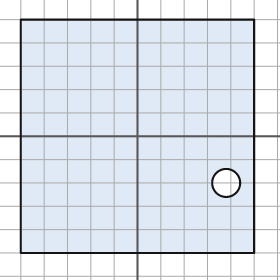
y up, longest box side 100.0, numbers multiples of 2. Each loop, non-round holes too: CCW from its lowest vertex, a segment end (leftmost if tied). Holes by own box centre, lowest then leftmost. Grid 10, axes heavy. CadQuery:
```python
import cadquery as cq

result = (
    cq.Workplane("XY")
    .moveTo(-50.0, -50.0)
    .lineTo(50.0, -50.0)
    .lineTo(50.0, 50.0)
    .lineTo(-50.0, 50.0)
    .close()
    .moveTo(38.0, -20.0)
    .circle(6.0)
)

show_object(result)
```